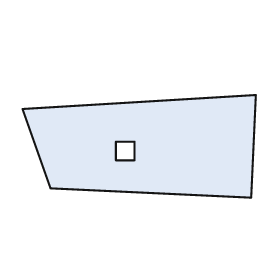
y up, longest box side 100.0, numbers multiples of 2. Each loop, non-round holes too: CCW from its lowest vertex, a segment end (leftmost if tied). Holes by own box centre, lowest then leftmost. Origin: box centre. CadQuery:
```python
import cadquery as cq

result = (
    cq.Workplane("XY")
    .moveTo(48.0, -22.0)
    .lineTo(50.0, 22.0)
    .lineTo(-50.0, 16.0)
    .lineTo(-38.0, -18.0)
    .close()
    .moveTo(-10.0, -6.0)
    .lineTo(-2.0, -6.0)
    .lineTo(-2.0, 2.0)
    .lineTo(-10.0, 2.0)
    .close()
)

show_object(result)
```